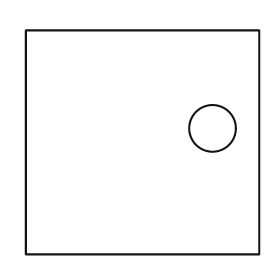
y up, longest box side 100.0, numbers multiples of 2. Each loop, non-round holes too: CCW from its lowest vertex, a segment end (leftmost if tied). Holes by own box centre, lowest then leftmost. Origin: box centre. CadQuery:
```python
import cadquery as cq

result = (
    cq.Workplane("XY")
    .moveTo(-50.0, -48.0)
    .lineTo(50.0, -48.0)
    .lineTo(50.0, 48.0)
    .lineTo(-50.0, 48.0)
    .close()
    .moveTo(30.0, 6.0)
    .circle(10.0)
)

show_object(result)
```